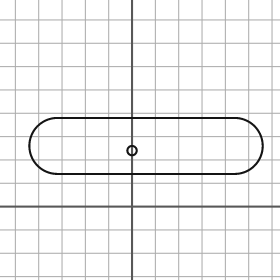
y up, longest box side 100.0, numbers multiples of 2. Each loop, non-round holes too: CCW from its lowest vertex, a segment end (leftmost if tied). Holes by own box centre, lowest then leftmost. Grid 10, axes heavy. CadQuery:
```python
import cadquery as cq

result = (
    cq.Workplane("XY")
    .moveTo(-32.0, 14.0)
    .lineTo(44.0, 14.0)
    .threePointArc((56.0, 26.0), (44.0, 38.0))
    .lineTo(-32.0, 38.0)
    .threePointArc((-44.0, 26.0), (-32.0, 14.0))
    .close()
    .moveTo(0.0, 24.0)
    .circle(2.0)
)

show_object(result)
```